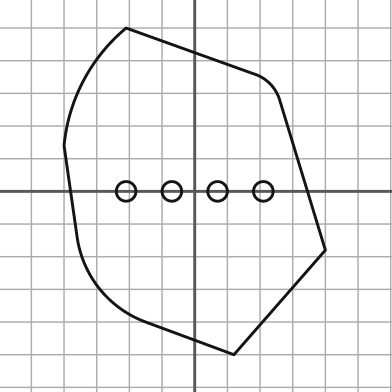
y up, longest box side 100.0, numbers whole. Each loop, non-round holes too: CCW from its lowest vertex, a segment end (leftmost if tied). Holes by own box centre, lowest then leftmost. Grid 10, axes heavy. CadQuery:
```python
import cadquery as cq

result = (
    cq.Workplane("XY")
    .moveTo(12.0, -50.0)
    .lineTo(40.0, -18.0)
    .lineTo(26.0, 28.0)
    .threePointArc((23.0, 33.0), (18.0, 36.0))
    .lineTo(-21.0, 50.0)
    .threePointArc((-34.0, 34.0), (-40.0, 14.0))
    .lineTo(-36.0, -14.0)
    .threePointArc((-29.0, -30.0), (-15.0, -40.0))
    .close()
    .moveTo(-21.0, 0.0)
    .circle(3.0)
    .moveTo(-7.0, 0.0)
    .circle(3.0)
    .moveTo(7.0, 0.0)
    .circle(3.0)
    .moveTo(21.0, 0.0)
    .circle(3.0)
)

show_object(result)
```